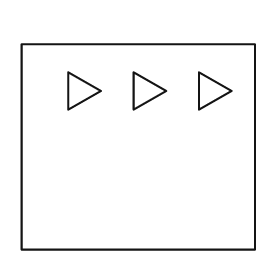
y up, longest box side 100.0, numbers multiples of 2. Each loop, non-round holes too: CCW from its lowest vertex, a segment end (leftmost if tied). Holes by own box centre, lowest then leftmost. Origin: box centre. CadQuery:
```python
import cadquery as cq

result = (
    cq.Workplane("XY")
    .moveTo(-50.0, -44.0)
    .lineTo(50.0, -44.0)
    .lineTo(50.0, 44.0)
    .lineTo(-50.0, 44.0)
    .close()
    .moveTo(-30.0, 16.0)
    .lineTo(-16.0, 24.0)
    .lineTo(-30.0, 32.0)
    .close()
    .moveTo(-2.0, 16.0)
    .lineTo(12.0, 24.0)
    .lineTo(-2.0, 32.0)
    .close()
    .moveTo(26.0, 16.0)
    .lineTo(40.0, 24.0)
    .lineTo(26.0, 32.0)
    .close()
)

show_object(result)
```